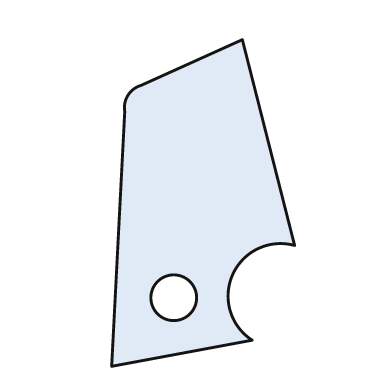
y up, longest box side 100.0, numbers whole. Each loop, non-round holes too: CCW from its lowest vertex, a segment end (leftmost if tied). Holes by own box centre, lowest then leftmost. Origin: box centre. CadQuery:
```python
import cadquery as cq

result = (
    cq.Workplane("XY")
    .moveTo(-28.0, -50.0)
    .lineTo(15.0, -42.0)
    .threePointArc((9.0, -22.0), (28.0, -13.0))
    .lineTo(12.0, 50.0)
    .lineTo(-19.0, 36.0)
    .threePointArc((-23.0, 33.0), (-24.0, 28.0))
    .close()
    .moveTo(-9.0, -29.0)
    .circle(7.0)
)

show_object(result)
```